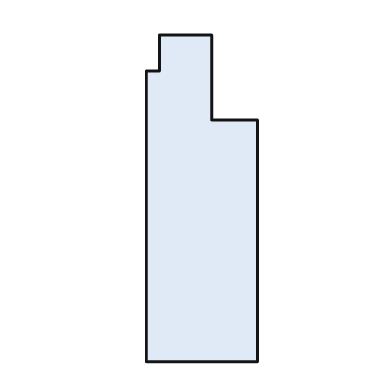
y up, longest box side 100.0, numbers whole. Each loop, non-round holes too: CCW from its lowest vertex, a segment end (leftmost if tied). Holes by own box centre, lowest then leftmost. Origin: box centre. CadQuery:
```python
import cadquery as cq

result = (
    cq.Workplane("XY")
    .moveTo(-17.0, -50.0)
    .lineTo(17.0, -50.0)
    .lineTo(17.0, 24.0)
    .lineTo(3.0, 24.0)
    .lineTo(3.0, 50.0)
    .lineTo(-13.0, 50.0)
    .lineTo(-13.0, 39.0)
    .lineTo(-17.0, 39.0)
    .close()
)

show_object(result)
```